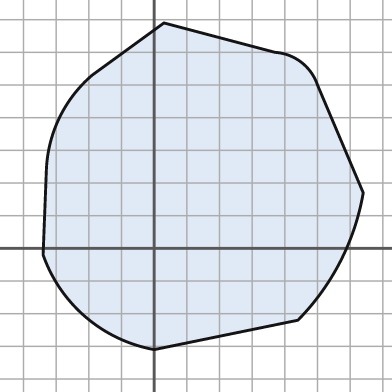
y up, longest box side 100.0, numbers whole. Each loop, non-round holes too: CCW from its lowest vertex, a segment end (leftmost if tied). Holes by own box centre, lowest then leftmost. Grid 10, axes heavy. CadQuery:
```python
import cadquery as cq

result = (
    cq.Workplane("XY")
    .moveTo(0.0, -31.0)
    .lineTo(44.0, -22.0)
    .threePointArc((57.0, -4.0), (64.0, 17.0))
    .lineTo(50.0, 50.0)
    .threePointArc((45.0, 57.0), (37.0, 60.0))
    .lineTo(3.0, 69.0)
    .lineTo(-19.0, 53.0)
    .threePointArc((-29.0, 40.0), (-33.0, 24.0))
    .lineTo(-34.0, -2.0)
    .threePointArc((-21.0, -21.0), (0.0, -31.0))
    .close()
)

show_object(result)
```